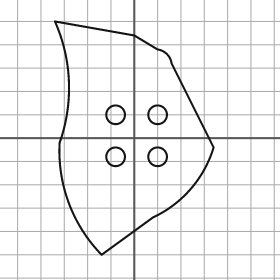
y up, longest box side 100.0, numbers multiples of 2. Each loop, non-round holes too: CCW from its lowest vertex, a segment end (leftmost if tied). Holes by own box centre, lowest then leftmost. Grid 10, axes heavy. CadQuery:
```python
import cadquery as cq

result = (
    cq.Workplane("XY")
    .moveTo(-14.0, -50.0)
    .lineTo(8.0, -34.0)
    .threePointArc((24.0, -22.0), (34.0, -4.0))
    .lineTo(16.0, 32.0)
    .threePointArc((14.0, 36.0), (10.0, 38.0))
    .lineTo(0.0, 44.0)
    .lineTo(-34.0, 50.0)
    .threePointArc((-28.0, 24.0), (-32.0, -2.0))
    .threePointArc((-28.0, -28.0), (-14.0, -50.0))
    .close()
    .moveTo(-8.0, -8.0)
    .circle(4.0)
    .moveTo(10.0, -8.0)
    .circle(4.0)
    .moveTo(-8.0, 10.0)
    .circle(4.0)
    .moveTo(10.0, 10.0)
    .circle(4.0)
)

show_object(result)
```